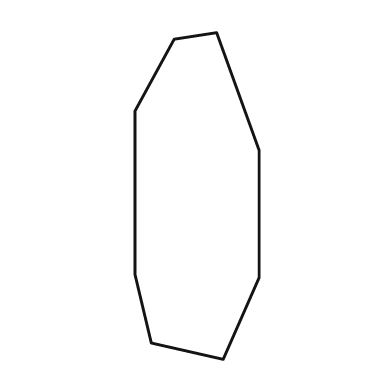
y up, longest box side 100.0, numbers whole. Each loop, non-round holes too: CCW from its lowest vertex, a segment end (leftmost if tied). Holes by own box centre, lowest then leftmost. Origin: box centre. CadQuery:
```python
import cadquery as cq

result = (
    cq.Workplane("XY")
    .moveTo(8.0, -50.0)
    .lineTo(19.0, -25.0)
    .lineTo(19.0, 14.0)
    .lineTo(6.0, 50.0)
    .lineTo(-7.0, 48.0)
    .lineTo(-19.0, 26.0)
    .lineTo(-19.0, -24.0)
    .lineTo(-14.0, -45.0)
    .close()
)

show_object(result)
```